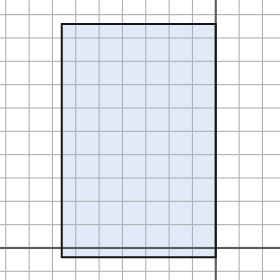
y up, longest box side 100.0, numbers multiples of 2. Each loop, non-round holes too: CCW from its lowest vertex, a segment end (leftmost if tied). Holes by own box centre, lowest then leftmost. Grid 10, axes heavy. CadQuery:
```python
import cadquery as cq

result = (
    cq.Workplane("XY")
    .moveTo(-66.0, -4.0)
    .lineTo(0.0, -4.0)
    .lineTo(0.0, 96.0)
    .lineTo(-66.0, 96.0)
    .close()
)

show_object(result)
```